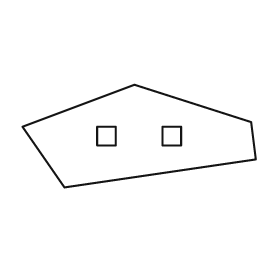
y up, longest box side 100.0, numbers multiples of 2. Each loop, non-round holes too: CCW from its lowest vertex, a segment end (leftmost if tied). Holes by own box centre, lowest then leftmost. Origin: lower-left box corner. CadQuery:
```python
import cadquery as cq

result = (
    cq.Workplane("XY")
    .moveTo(18.0, 0.0)
    .lineTo(100.0, 12.0)
    .lineTo(98.0, 28.0)
    .lineTo(48.0, 44.0)
    .lineTo(0.0, 26.0)
    .close()
    .moveTo(32.0, 18.0)
    .lineTo(40.0, 18.0)
    .lineTo(40.0, 26.0)
    .lineTo(32.0, 26.0)
    .close()
    .moveTo(60.0, 18.0)
    .lineTo(68.0, 18.0)
    .lineTo(68.0, 26.0)
    .lineTo(60.0, 26.0)
    .close()
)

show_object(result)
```